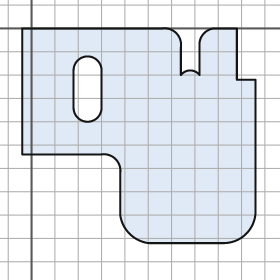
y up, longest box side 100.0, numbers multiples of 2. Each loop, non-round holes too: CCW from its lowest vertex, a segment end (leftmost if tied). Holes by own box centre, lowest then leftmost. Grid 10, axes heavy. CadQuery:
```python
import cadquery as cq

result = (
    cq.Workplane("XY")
    .moveTo(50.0, -92.0)
    .lineTo(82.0, -92.0)
    .threePointArc((92.0, -88.0), (96.0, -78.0))
    .lineTo(96.0, -22.0)
    .lineTo(88.0, -22.0)
    .lineTo(88.0, 0.0)
    .lineTo(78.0, 0.0)
    .threePointArc((74.0, -2.0), (72.0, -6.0))
    .lineTo(72.0, -20.0)
    .threePointArc((68.0, -18.0), (64.0, -20.0))
    .lineTo(64.0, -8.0)
    .threePointArc((62.0, -2.0), (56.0, 0.0))
    .lineTo(-4.0, 0.0)
    .lineTo(-4.0, -54.0)
    .lineTo(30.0, -54.0)
    .threePointArc((36.0, -56.0), (38.0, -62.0))
    .lineTo(38.0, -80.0)
    .threePointArc((42.0, -88.0), (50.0, -92.0))
    .close()
    .moveTo(18.0, -34.0)
    .threePointArc((24.0, -40.0), (30.0, -34.0))
    .lineTo(30.0, -18.0)
    .threePointArc((24.0, -12.0), (18.0, -18.0))
    .close()
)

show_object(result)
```